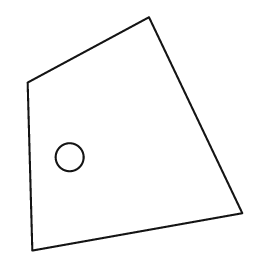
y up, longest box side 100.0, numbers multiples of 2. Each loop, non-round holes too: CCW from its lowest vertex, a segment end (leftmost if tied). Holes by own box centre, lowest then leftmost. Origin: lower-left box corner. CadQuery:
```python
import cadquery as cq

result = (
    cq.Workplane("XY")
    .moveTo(2.0, 0.0)
    .lineTo(92.0, 16.0)
    .lineTo(52.0, 100.0)
    .lineTo(0.0, 72.0)
    .close()
    .moveTo(18.0, 40.0)
    .circle(6.0)
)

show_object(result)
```